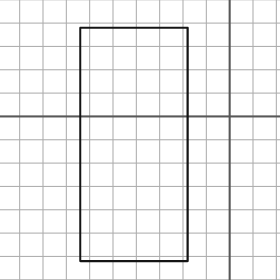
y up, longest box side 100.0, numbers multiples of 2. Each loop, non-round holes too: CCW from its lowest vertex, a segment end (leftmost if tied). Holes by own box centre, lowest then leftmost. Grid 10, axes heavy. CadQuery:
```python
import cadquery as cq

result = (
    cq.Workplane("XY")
    .moveTo(-64.0, -62.0)
    .lineTo(-18.0, -62.0)
    .lineTo(-18.0, 38.0)
    .lineTo(-64.0, 38.0)
    .close()
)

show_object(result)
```